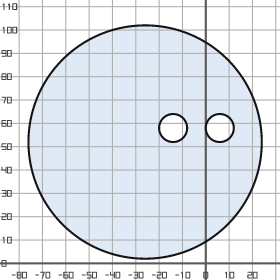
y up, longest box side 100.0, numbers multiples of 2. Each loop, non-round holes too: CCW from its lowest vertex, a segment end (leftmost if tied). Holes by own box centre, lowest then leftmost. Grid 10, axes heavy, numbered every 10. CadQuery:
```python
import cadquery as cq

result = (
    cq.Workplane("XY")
    .moveTo(-26.0, 52.0)
    .circle(50.0)
    .moveTo(-14.0, 58.0)
    .circle(6.0)
    .moveTo(6.0, 58.0)
    .circle(6.0)
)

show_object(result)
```